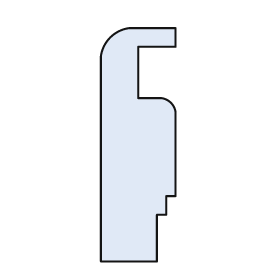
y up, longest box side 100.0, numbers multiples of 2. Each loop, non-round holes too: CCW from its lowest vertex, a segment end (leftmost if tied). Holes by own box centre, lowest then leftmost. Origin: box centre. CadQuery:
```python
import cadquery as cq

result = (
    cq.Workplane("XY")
    .moveTo(-16.0, -50.0)
    .lineTo(8.0, -50.0)
    .lineTo(8.0, -30.0)
    .lineTo(12.0, -30.0)
    .lineTo(12.0, -22.0)
    .lineTo(16.0, -22.0)
    .lineTo(16.0, 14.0)
    .threePointArc((14.0, 18.0), (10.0, 20.0))
    .lineTo(0.0, 20.0)
    .lineTo(0.0, 42.0)
    .lineTo(16.0, 42.0)
    .lineTo(16.0, 50.0)
    .lineTo(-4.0, 50.0)
    .threePointArc((-12.0, 46.0), (-16.0, 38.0))
    .close()
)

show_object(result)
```